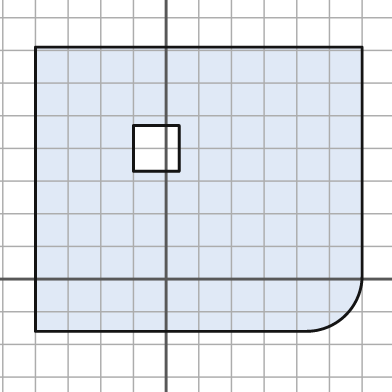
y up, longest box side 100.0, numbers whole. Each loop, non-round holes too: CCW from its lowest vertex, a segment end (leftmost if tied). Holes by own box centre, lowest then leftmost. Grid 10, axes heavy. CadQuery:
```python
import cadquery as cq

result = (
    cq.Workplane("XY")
    .moveTo(-40.0, -16.0)
    .lineTo(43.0, -16.0)
    .threePointArc((55.0, -11.0), (60.0, 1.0))
    .lineTo(60.0, 71.0)
    .lineTo(-40.0, 71.0)
    .close()
    .moveTo(-10.0, 33.0)
    .lineTo(4.0, 33.0)
    .lineTo(4.0, 47.0)
    .lineTo(-10.0, 47.0)
    .close()
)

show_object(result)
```